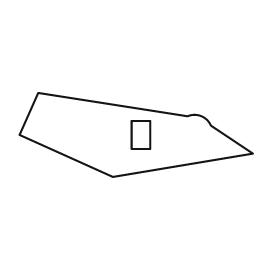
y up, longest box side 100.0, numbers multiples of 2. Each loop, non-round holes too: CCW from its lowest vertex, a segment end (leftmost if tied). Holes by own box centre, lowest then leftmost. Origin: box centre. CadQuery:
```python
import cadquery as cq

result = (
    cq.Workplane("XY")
    .moveTo(-10.0, -18.0)
    .lineTo(50.0, -8.0)
    .lineTo(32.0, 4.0)
    .threePointArc((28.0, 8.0), (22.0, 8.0))
    .lineTo(-42.0, 18.0)
    .lineTo(-50.0, 0.0)
    .close()
    .moveTo(-2.0, -6.0)
    .lineTo(6.0, -6.0)
    .lineTo(6.0, 6.0)
    .lineTo(-2.0, 6.0)
    .close()
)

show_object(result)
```